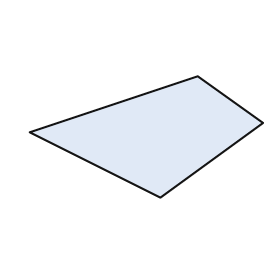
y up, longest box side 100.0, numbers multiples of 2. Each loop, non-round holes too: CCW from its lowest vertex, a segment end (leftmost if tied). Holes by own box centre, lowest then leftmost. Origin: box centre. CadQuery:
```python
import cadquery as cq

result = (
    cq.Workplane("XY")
    .moveTo(6.0, -26.0)
    .lineTo(50.0, 6.0)
    .lineTo(22.0, 26.0)
    .lineTo(-50.0, 2.0)
    .close()
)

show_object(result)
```